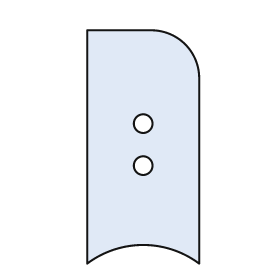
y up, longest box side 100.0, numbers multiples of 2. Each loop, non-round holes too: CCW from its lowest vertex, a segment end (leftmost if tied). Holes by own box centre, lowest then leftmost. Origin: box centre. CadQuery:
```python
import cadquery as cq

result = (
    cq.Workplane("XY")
    .moveTo(-24.0, -50.0)
    .threePointArc((0.0, -42.0), (24.0, -50.0))
    .lineTo(24.0, 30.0)
    .threePointArc((18.0, 44.0), (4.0, 50.0))
    .lineTo(-24.0, 50.0)
    .close()
    .moveTo(0.0, -8.0)
    .circle(4.0)
    .moveTo(0.0, 10.0)
    .circle(4.0)
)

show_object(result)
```